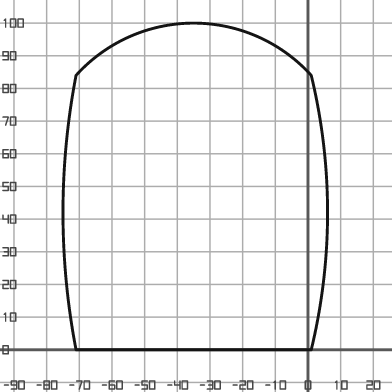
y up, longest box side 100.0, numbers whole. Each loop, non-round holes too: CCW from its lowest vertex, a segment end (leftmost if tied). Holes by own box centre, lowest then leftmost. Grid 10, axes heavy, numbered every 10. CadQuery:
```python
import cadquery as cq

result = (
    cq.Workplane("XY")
    .moveTo(-71.0, 0.0)
    .lineTo(1.0, 0.0)
    .threePointArc((6.0, 42.0), (1.0, 84.0))
    .threePointArc((-35.0, 100.0), (-71.0, 84.0))
    .threePointArc((-75.0, 42.0), (-71.0, 0.0))
    .close()
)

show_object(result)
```